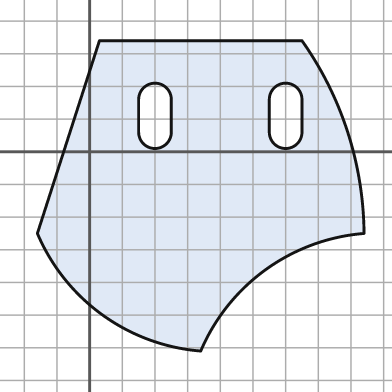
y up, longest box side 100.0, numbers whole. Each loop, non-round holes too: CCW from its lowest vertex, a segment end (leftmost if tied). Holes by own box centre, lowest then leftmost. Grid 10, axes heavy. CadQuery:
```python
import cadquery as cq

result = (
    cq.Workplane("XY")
    .moveTo(34.0, -61.0)
    .threePointArc((54.0, -36.0), (84.0, -25.0))
    .threePointArc((79.0, 6.0), (65.0, 34.0))
    .lineTo(3.0, 34.0)
    .lineTo(-16.0, -25.0)
    .threePointArc((4.0, -50.0), (34.0, -61.0))
    .close()
    .moveTo(15.0, 6.0)
    .threePointArc((20.0, 1.0), (25.0, 6.0))
    .lineTo(25.0, 16.0)
    .threePointArc((20.0, 21.0), (15.0, 16.0))
    .close()
    .moveTo(55.0, 6.0)
    .threePointArc((60.0, 1.0), (65.0, 6.0))
    .lineTo(65.0, 16.0)
    .threePointArc((60.0, 21.0), (55.0, 16.0))
    .close()
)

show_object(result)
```